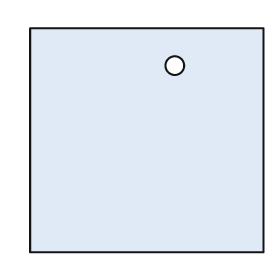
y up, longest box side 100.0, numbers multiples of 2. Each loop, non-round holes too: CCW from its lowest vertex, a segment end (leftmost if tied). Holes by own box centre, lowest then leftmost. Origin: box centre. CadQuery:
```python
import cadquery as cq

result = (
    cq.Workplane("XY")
    .moveTo(-50.0, -48.0)
    .lineTo(50.0, -48.0)
    .lineTo(50.0, 48.0)
    .lineTo(-50.0, 48.0)
    .close()
    .moveTo(12.0, 32.0)
    .circle(4.0)
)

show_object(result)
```